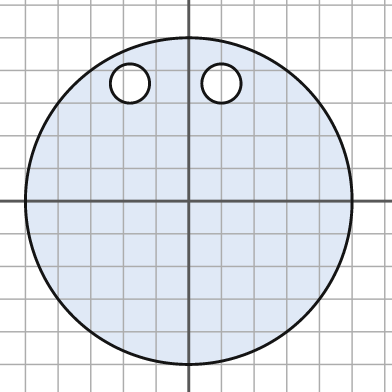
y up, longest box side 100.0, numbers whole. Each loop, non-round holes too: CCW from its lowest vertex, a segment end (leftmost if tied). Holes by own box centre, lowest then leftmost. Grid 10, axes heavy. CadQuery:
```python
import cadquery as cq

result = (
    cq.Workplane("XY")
    .moveTo(0.0, 0.0)
    .circle(50.0)
    .moveTo(-18.0, 36.0)
    .circle(6.0)
    .moveTo(10.0, 36.0)
    .circle(6.0)
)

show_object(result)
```